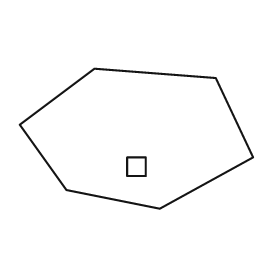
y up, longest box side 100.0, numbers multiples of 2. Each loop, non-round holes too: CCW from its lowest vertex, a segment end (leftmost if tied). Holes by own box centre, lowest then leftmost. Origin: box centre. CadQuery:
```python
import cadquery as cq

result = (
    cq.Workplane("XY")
    .moveTo(10.0, -30.0)
    .lineTo(50.0, -8.0)
    .lineTo(34.0, 26.0)
    .lineTo(-18.0, 30.0)
    .lineTo(-50.0, 6.0)
    .lineTo(-30.0, -22.0)
    .close()
    .moveTo(-4.0, -16.0)
    .lineTo(4.0, -16.0)
    .lineTo(4.0, -8.0)
    .lineTo(-4.0, -8.0)
    .close()
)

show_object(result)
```